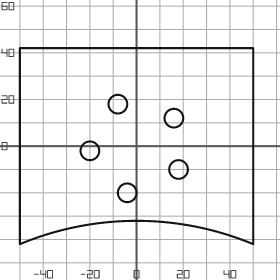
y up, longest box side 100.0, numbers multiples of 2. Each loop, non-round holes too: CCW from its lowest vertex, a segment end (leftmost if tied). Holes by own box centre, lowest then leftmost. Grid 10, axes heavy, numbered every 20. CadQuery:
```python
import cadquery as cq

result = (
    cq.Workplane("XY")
    .moveTo(-50.0, -42.0)
    .threePointArc((0.0, -32.0), (50.0, -42.0))
    .lineTo(50.0, 42.0)
    .lineTo(-50.0, 42.0)
    .close()
    .moveTo(-4.0, -20.0)
    .circle(4.0)
    .moveTo(18.0, -10.0)
    .circle(4.0)
    .moveTo(-20.0, -2.0)
    .circle(4.0)
    .moveTo(16.0, 12.0)
    .circle(4.0)
    .moveTo(-8.0, 18.0)
    .circle(4.0)
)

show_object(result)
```